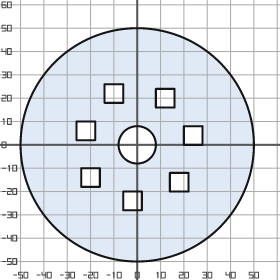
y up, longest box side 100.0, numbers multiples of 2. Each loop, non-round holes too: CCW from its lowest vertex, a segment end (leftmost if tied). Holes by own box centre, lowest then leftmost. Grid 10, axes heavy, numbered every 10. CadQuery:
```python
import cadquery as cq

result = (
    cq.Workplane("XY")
    .moveTo(0.0, 0.0)
    .circle(50.0)
    .moveTo(-6.0, -28.0)
    .lineTo(2.0, -28.0)
    .lineTo(2.0, -20.0)
    .lineTo(-6.0, -20.0)
    .close()
    .moveTo(14.0, -20.0)
    .lineTo(22.0, -20.0)
    .lineTo(22.0, -12.0)
    .lineTo(14.0, -12.0)
    .close()
    .moveTo(-24.0, -18.0)
    .lineTo(-16.0, -18.0)
    .lineTo(-16.0, -10.0)
    .lineTo(-24.0, -10.0)
    .close()
    .moveTo(0.0, 0.0)
    .circle(8.0)
    .moveTo(20.0, 0.0)
    .lineTo(28.0, 0.0)
    .lineTo(28.0, 8.0)
    .lineTo(20.0, 8.0)
    .close()
    .moveTo(-26.0, 2.0)
    .lineTo(-18.0, 2.0)
    .lineTo(-18.0, 10.0)
    .lineTo(-26.0, 10.0)
    .close()
    .moveTo(8.0, 16.0)
    .lineTo(16.0, 16.0)
    .lineTo(16.0, 24.0)
    .lineTo(8.0, 24.0)
    .close()
    .moveTo(-14.0, 18.0)
    .lineTo(-6.0, 18.0)
    .lineTo(-6.0, 26.0)
    .lineTo(-14.0, 26.0)
    .close()
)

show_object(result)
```